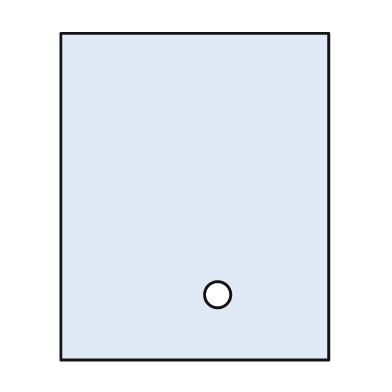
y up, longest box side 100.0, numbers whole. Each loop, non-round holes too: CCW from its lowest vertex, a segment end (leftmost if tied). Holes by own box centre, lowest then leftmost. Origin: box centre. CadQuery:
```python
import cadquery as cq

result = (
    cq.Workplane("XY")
    .moveTo(-41.0, -50.0)
    .lineTo(41.0, -50.0)
    .lineTo(41.0, 50.0)
    .lineTo(-41.0, 50.0)
    .close()
    .moveTo(7.0, -30.0)
    .circle(4.0)
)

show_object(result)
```